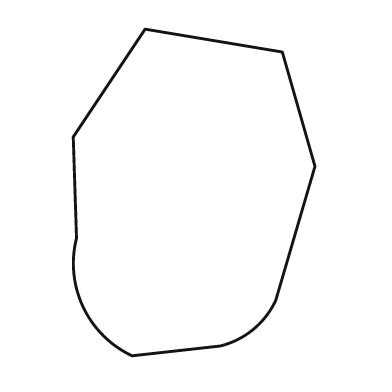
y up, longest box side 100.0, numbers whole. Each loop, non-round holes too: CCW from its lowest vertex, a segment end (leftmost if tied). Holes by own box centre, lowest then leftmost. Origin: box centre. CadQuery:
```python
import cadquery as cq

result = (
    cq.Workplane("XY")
    .moveTo(-19.0, -50.0)
    .lineTo(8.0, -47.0)
    .threePointArc((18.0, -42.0), (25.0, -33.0))
    .lineTo(37.0, 8.0)
    .lineTo(27.0, 43.0)
    .lineTo(-15.0, 50.0)
    .lineTo(-37.0, 17.0)
    .lineTo(-36.0, -14.0)
    .threePointArc((-34.0, -35.0), (-19.0, -50.0))
    .close()
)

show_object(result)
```